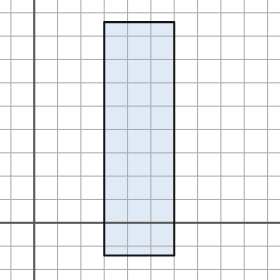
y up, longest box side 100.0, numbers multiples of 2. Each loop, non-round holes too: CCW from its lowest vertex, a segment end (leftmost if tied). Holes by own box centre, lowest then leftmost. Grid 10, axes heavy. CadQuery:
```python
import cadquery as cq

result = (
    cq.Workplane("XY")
    .moveTo(30.0, -14.0)
    .lineTo(60.0, -14.0)
    .lineTo(60.0, 86.0)
    .lineTo(30.0, 86.0)
    .close()
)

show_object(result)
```